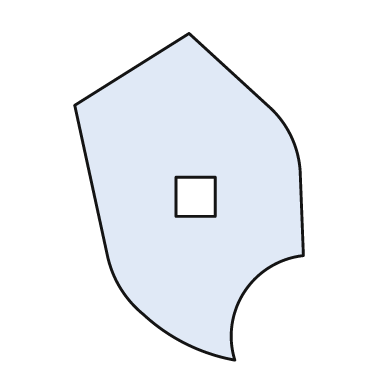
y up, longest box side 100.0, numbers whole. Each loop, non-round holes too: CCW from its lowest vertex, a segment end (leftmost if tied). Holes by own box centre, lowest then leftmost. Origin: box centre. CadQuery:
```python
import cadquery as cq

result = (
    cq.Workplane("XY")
    .moveTo(14.0, -50.0)
    .threePointArc((17.0, -29.0), (35.0, -18.0))
    .lineTo(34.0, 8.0)
    .threePointArc((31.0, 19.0), (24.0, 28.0))
    .lineTo(0.0, 50.0)
    .lineTo(-35.0, 28.0)
    .lineTo(-25.0, -18.0)
    .threePointArc((-21.0, -28.0), (-14.0, -36.0))
    .threePointArc((-1.0, -45.0), (14.0, -50.0))
    .close()
    .moveTo(-4.0, -6.0)
    .lineTo(8.0, -6.0)
    .lineTo(8.0, 6.0)
    .lineTo(-4.0, 6.0)
    .close()
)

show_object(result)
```